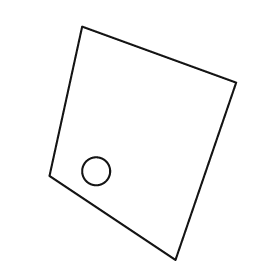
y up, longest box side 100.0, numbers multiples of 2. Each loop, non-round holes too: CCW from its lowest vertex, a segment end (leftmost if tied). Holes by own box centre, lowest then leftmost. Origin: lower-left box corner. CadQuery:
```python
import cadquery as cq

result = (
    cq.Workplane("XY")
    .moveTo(54.0, 0.0)
    .lineTo(80.0, 76.0)
    .lineTo(14.0, 100.0)
    .lineTo(0.0, 36.0)
    .close()
    .moveTo(20.0, 38.0)
    .circle(6.0)
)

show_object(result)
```